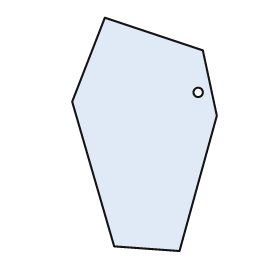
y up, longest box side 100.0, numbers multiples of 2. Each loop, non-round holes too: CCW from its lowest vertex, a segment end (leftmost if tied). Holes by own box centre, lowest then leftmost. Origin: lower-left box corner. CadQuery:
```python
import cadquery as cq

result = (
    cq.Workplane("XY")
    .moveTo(46.0, 0.0)
    .lineTo(62.0, 58.0)
    .lineTo(56.0, 86.0)
    .lineTo(14.0, 100.0)
    .lineTo(0.0, 64.0)
    .lineTo(18.0, 2.0)
    .close()
    .moveTo(54.0, 68.0)
    .circle(2.0)
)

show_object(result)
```